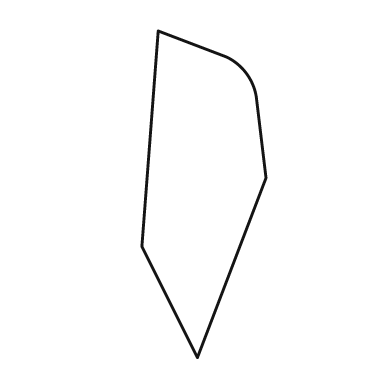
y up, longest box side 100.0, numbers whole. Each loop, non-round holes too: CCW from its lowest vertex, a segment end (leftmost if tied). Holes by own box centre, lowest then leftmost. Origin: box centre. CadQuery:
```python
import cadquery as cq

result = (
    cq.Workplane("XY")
    .moveTo(-2.0, -50.0)
    .lineTo(19.0, 5.0)
    .lineTo(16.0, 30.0)
    .threePointArc((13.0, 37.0), (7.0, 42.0))
    .lineTo(-14.0, 50.0)
    .lineTo(-19.0, -16.0)
    .close()
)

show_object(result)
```